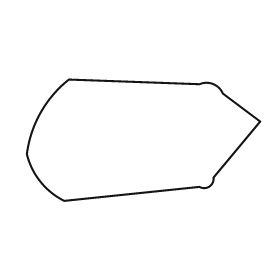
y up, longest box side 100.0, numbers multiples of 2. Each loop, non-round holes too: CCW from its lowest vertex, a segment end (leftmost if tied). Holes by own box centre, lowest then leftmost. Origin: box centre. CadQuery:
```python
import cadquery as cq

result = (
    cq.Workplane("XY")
    .moveTo(-34.0, -26.0)
    .lineTo(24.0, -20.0)
    .threePointArc((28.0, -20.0), (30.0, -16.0))
    .lineTo(50.0, 8.0)
    .lineTo(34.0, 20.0)
    .threePointArc((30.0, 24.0), (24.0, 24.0))
    .lineTo(-32.0, 26.0)
    .threePointArc((-44.0, 12.0), (-50.0, -6.0))
    .threePointArc((-44.0, -18.0), (-34.0, -26.0))
    .close()
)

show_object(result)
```